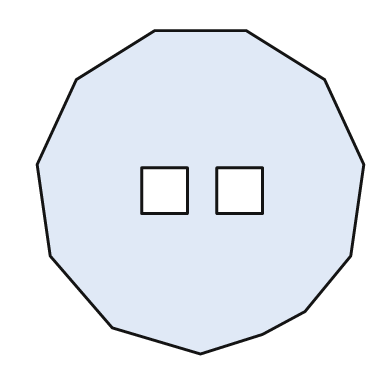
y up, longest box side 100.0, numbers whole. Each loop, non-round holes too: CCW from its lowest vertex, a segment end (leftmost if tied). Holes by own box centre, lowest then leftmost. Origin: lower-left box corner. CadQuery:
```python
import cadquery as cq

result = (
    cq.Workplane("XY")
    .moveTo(50.0, 0.0)
    .lineTo(69.0, 6.0)
    .lineTo(82.0, 13.0)
    .lineTo(96.0, 30.0)
    .lineTo(100.0, 58.0)
    .lineTo(88.0, 84.0)
    .lineTo(64.0, 99.0)
    .lineTo(36.0, 99.0)
    .lineTo(12.0, 84.0)
    .lineTo(0.0, 58.0)
    .lineTo(4.0, 30.0)
    .lineTo(23.0, 8.0)
    .close()
    .moveTo(32.0, 43.0)
    .lineTo(46.0, 43.0)
    .lineTo(46.0, 57.0)
    .lineTo(32.0, 57.0)
    .close()
    .moveTo(55.0, 43.0)
    .lineTo(69.0, 43.0)
    .lineTo(69.0, 57.0)
    .lineTo(55.0, 57.0)
    .close()
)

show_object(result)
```